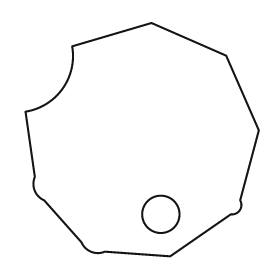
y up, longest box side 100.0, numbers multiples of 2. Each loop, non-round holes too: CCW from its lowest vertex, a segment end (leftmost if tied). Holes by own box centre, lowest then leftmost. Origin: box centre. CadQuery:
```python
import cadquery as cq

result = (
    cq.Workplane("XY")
    .moveTo(12.0, -50.0)
    .lineTo(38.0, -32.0)
    .threePointArc((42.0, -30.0), (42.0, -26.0))
    .lineTo(50.0, 4.0)
    .lineTo(36.0, 36.0)
    .lineTo(4.0, 50.0)
    .lineTo(-30.0, 40.0)
    .threePointArc((-34.0, 22.0), (-50.0, 12.0))
    .lineTo(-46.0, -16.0)
    .threePointArc((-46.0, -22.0), (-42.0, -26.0))
    .lineTo(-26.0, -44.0)
    .threePointArc((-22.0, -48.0), (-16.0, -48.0))
    .close()
    .moveTo(8.0, -32.0)
    .circle(8.0)
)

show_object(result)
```